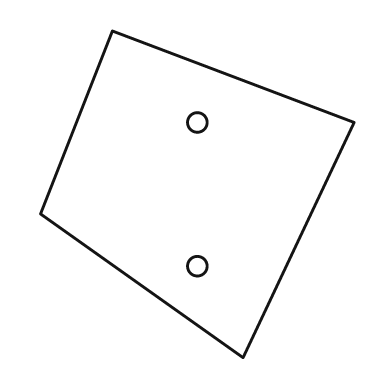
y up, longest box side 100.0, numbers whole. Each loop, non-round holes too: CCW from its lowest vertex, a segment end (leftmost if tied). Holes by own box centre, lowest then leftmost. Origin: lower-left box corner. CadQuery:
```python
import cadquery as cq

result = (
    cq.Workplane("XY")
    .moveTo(62.0, 0.0)
    .lineTo(96.0, 72.0)
    .lineTo(22.0, 100.0)
    .lineTo(0.0, 44.0)
    .close()
    .moveTo(48.0, 28.0)
    .circle(3.0)
    .moveTo(48.0, 72.0)
    .circle(3.0)
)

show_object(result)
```